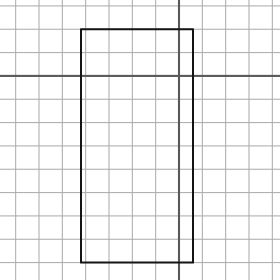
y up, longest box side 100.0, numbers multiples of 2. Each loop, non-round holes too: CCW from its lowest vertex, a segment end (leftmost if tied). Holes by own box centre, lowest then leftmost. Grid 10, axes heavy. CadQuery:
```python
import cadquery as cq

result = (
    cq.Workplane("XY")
    .moveTo(-42.0, -80.0)
    .lineTo(6.0, -80.0)
    .lineTo(6.0, 20.0)
    .lineTo(-42.0, 20.0)
    .close()
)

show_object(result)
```